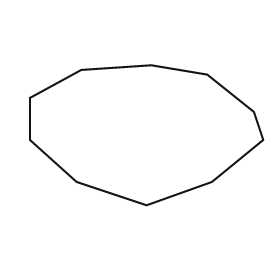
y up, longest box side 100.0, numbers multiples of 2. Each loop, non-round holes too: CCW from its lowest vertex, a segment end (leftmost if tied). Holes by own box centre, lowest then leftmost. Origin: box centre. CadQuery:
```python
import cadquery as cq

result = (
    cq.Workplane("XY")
    .moveTo(0.0, -30.0)
    .lineTo(28.0, -20.0)
    .lineTo(50.0, -2.0)
    .lineTo(46.0, 10.0)
    .lineTo(26.0, 26.0)
    .lineTo(2.0, 30.0)
    .lineTo(-28.0, 28.0)
    .lineTo(-50.0, 16.0)
    .lineTo(-50.0, -2.0)
    .lineTo(-30.0, -20.0)
    .close()
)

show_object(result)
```